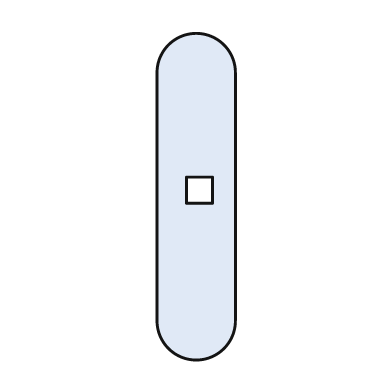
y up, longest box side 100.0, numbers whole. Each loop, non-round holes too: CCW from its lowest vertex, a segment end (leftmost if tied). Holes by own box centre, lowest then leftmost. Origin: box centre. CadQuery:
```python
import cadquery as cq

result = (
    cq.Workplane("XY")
    .moveTo(-12.0, -38.0)
    .threePointArc((0.0, -50.0), (12.0, -38.0))
    .lineTo(12.0, 38.0)
    .threePointArc((0.0, 50.0), (-12.0, 38.0))
    .close()
    .moveTo(-3.0, -2.0)
    .lineTo(5.0, -2.0)
    .lineTo(5.0, 6.0)
    .lineTo(-3.0, 6.0)
    .close()
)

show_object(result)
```